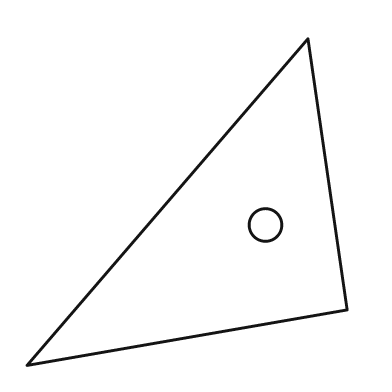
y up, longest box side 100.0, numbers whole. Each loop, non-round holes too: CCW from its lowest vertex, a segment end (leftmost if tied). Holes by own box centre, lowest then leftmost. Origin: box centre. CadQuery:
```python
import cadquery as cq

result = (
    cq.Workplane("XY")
    .moveTo(-49.0, -50.0)
    .lineTo(49.0, -33.0)
    .lineTo(37.0, 50.0)
    .close()
    .moveTo(24.0, -7.0)
    .circle(5.0)
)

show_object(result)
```